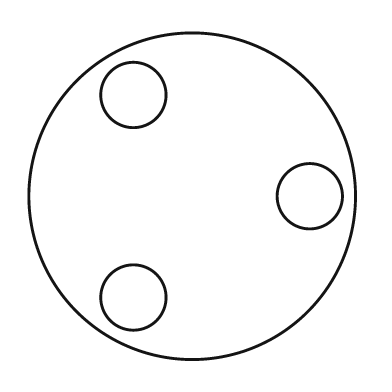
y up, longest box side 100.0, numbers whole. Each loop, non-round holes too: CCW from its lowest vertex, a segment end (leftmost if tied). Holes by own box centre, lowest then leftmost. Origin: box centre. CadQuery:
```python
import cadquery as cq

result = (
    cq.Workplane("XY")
    .moveTo(0.0, 0.0)
    .circle(50.0)
    .moveTo(-18.0, -31.0)
    .circle(10.0)
    .moveTo(36.0, 0.0)
    .circle(10.0)
    .moveTo(-18.0, 31.0)
    .circle(10.0)
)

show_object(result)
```